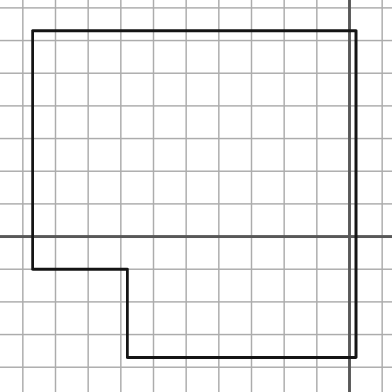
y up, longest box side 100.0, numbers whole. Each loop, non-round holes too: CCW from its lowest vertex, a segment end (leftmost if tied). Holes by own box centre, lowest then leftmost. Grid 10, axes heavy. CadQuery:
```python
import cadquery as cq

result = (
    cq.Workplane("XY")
    .moveTo(-68.0, -37.0)
    .lineTo(2.0, -37.0)
    .lineTo(2.0, 63.0)
    .lineTo(-97.0, 63.0)
    .lineTo(-97.0, -10.0)
    .lineTo(-68.0, -10.0)
    .close()
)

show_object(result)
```